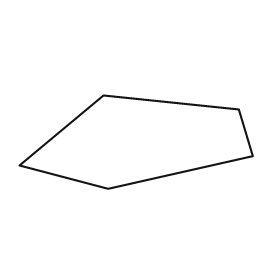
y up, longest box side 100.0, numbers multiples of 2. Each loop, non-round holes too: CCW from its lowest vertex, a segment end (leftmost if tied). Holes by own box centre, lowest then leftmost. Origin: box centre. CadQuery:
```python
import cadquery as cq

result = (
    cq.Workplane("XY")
    .moveTo(-12.0, -20.0)
    .lineTo(50.0, -6.0)
    .lineTo(44.0, 14.0)
    .lineTo(-14.0, 20.0)
    .lineTo(-50.0, -10.0)
    .close()
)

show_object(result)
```